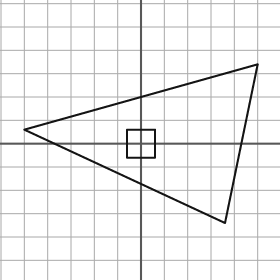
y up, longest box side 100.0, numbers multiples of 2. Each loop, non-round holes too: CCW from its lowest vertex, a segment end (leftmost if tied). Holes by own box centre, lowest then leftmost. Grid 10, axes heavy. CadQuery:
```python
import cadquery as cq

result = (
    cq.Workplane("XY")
    .moveTo(36.0, -34.0)
    .lineTo(50.0, 34.0)
    .lineTo(-50.0, 6.0)
    .close()
    .moveTo(-6.0, -6.0)
    .lineTo(6.0, -6.0)
    .lineTo(6.0, 6.0)
    .lineTo(-6.0, 6.0)
    .close()
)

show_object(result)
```